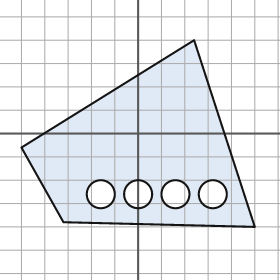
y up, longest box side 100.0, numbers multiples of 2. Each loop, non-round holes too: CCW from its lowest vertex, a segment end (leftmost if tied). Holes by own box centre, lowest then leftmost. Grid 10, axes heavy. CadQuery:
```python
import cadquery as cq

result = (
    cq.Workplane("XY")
    .moveTo(50.0, -40.0)
    .lineTo(24.0, 40.0)
    .lineTo(-50.0, -6.0)
    .lineTo(-32.0, -38.0)
    .close()
    .moveTo(-16.0, -26.0)
    .circle(6.0)
    .moveTo(0.0, -26.0)
    .circle(6.0)
    .moveTo(16.0, -26.0)
    .circle(6.0)
    .moveTo(32.0, -26.0)
    .circle(6.0)
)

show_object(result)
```